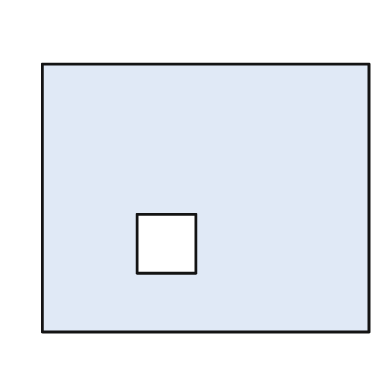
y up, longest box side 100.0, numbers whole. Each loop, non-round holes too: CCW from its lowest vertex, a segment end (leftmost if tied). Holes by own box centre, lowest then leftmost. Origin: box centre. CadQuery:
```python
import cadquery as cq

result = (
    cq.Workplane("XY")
    .moveTo(-50.0, -41.0)
    .lineTo(50.0, -41.0)
    .lineTo(50.0, 41.0)
    .lineTo(-50.0, 41.0)
    .close()
    .moveTo(-21.0, -23.0)
    .lineTo(-3.0, -23.0)
    .lineTo(-3.0, -5.0)
    .lineTo(-21.0, -5.0)
    .close()
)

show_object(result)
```